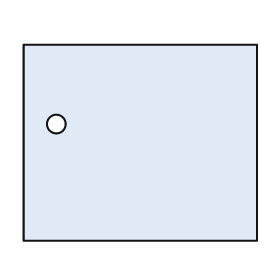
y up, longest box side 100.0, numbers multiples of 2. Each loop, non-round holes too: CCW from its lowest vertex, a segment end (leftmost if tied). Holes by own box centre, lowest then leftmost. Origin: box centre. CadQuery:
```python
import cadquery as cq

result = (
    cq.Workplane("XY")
    .moveTo(-50.0, -42.0)
    .lineTo(50.0, -42.0)
    .lineTo(50.0, 42.0)
    .lineTo(-50.0, 42.0)
    .close()
    .moveTo(-36.0, 8.0)
    .circle(4.0)
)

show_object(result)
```